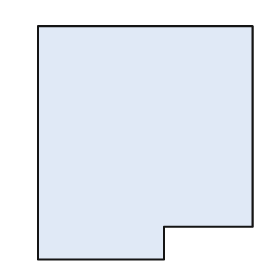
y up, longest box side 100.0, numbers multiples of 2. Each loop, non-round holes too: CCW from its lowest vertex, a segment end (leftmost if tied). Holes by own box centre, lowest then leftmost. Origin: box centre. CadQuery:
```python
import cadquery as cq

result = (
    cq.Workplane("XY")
    .moveTo(-46.0, -50.0)
    .lineTo(8.0, -50.0)
    .lineTo(8.0, -36.0)
    .lineTo(46.0, -36.0)
    .lineTo(46.0, 50.0)
    .lineTo(-46.0, 50.0)
    .close()
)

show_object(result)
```